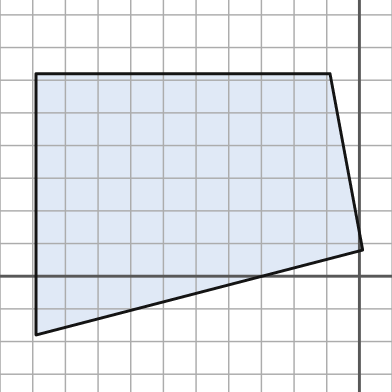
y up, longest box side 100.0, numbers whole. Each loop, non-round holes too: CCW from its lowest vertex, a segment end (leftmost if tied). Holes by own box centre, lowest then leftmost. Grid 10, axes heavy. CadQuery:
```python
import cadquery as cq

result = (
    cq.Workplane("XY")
    .moveTo(-99.0, -18.0)
    .lineTo(1.0, 8.0)
    .lineTo(-9.0, 62.0)
    .lineTo(-99.0, 62.0)
    .close()
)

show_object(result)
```